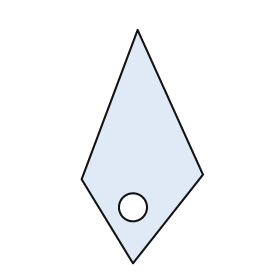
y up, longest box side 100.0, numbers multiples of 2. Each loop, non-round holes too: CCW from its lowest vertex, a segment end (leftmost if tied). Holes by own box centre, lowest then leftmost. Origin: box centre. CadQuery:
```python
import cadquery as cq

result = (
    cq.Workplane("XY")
    .moveTo(-4.0, -50.0)
    .lineTo(26.0, -12.0)
    .lineTo(-2.0, 50.0)
    .lineTo(-26.0, -14.0)
    .close()
    .moveTo(-4.0, -26.0)
    .circle(6.0)
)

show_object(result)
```